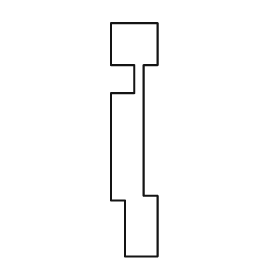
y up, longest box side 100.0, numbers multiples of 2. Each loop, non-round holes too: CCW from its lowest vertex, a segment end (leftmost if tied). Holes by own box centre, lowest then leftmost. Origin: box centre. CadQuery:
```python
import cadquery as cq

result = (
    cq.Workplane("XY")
    .moveTo(-4.0, -50.0)
    .lineTo(10.0, -50.0)
    .lineTo(10.0, -24.0)
    .lineTo(4.0, -24.0)
    .lineTo(4.0, 32.0)
    .lineTo(10.0, 32.0)
    .lineTo(10.0, 50.0)
    .lineTo(-10.0, 50.0)
    .lineTo(-10.0, 32.0)
    .lineTo(0.0, 32.0)
    .lineTo(0.0, 20.0)
    .lineTo(-10.0, 20.0)
    .lineTo(-10.0, -26.0)
    .lineTo(-4.0, -26.0)
    .close()
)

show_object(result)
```